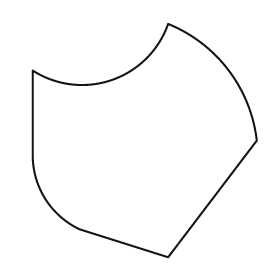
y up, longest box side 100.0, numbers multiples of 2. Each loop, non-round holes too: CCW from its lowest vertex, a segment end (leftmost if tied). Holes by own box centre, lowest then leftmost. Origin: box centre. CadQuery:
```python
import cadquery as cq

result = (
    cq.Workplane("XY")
    .moveTo(10.0, -50.0)
    .lineTo(48.0, 0.0)
    .threePointArc((36.0, 30.0), (10.0, 50.0))
    .threePointArc((-14.0, 26.0), (-48.0, 30.0))
    .lineTo(-48.0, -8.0)
    .threePointArc((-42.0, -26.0), (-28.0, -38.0))
    .close()
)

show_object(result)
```